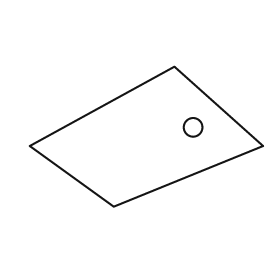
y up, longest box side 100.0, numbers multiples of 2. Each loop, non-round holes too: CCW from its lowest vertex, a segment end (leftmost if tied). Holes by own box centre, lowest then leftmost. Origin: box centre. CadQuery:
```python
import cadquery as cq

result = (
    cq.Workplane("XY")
    .moveTo(-14.0, -30.0)
    .lineTo(50.0, -4.0)
    .lineTo(12.0, 30.0)
    .lineTo(-50.0, -4.0)
    .close()
    .moveTo(20.0, 4.0)
    .circle(4.0)
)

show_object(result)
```